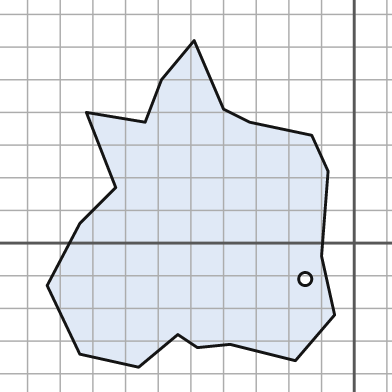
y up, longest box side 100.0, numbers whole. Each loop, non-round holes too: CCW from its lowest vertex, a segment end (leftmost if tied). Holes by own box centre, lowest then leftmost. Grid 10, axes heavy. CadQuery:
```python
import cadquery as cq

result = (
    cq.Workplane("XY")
    .moveTo(-66.0, -38.0)
    .lineTo(-54.0, -28.0)
    .lineTo(-48.0, -32.0)
    .lineTo(-38.0, -31.0)
    .lineTo(-18.0, -36.0)
    .lineTo(-6.0, -22.0)
    .lineTo(-10.0, -4.0)
    .lineTo(-8.0, 22.0)
    .lineTo(-13.0, 33.0)
    .lineTo(-32.0, 37.0)
    .lineTo(-40.0, 41.0)
    .lineTo(-49.0, 62.0)
    .lineTo(-59.0, 50.0)
    .lineTo(-64.0, 37.0)
    .lineTo(-82.0, 40.0)
    .lineTo(-73.0, 17.0)
    .lineTo(-84.0, 6.0)
    .lineTo(-94.0, -13.0)
    .lineTo(-84.0, -34.0)
    .close()
    .moveTo(-15.0, -11.0)
    .circle(2.0)
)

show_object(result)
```